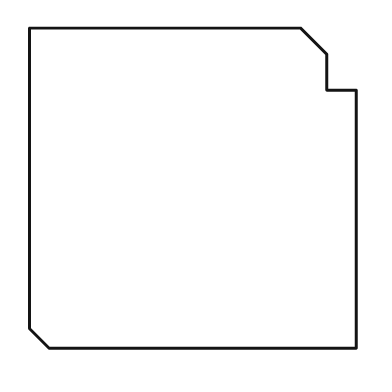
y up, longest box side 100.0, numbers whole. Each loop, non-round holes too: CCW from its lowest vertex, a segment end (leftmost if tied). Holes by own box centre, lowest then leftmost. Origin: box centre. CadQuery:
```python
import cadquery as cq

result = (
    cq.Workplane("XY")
    .moveTo(-44.0, -49.0)
    .lineTo(50.0, -49.0)
    .lineTo(50.0, 30.0)
    .lineTo(41.0, 30.0)
    .lineTo(41.0, 41.0)
    .lineTo(33.0, 49.0)
    .lineTo(-50.0, 49.0)
    .lineTo(-50.0, -43.0)
    .close()
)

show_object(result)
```